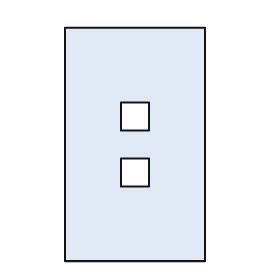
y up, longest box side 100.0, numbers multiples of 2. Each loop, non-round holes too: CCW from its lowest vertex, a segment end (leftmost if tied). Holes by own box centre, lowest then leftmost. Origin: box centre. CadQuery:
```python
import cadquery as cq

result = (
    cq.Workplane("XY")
    .moveTo(-30.0, -50.0)
    .lineTo(30.0, -50.0)
    .lineTo(30.0, 50.0)
    .lineTo(-30.0, 50.0)
    .close()
    .moveTo(-6.0, -18.0)
    .lineTo(6.0, -18.0)
    .lineTo(6.0, -6.0)
    .lineTo(-6.0, -6.0)
    .close()
    .moveTo(-6.0, 6.0)
    .lineTo(6.0, 6.0)
    .lineTo(6.0, 18.0)
    .lineTo(-6.0, 18.0)
    .close()
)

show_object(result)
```